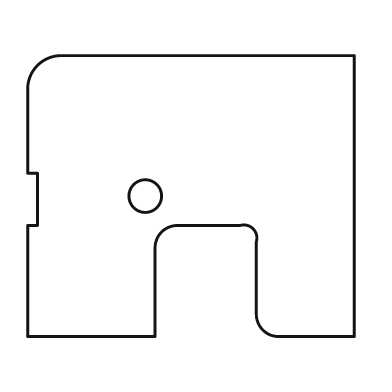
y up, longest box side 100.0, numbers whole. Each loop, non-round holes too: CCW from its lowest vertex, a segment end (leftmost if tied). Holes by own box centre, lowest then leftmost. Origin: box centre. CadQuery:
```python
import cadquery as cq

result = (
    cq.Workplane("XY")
    .moveTo(-50.0, -43.0)
    .lineTo(-11.0, -43.0)
    .lineTo(-11.0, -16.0)
    .threePointArc((-9.0, -11.0), (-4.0, -9.0))
    .lineTo(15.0, -9.0)
    .threePointArc((19.0, -10.0), (20.0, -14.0))
    .lineTo(20.0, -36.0)
    .threePointArc((22.0, -41.0), (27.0, -43.0))
    .lineTo(50.0, -43.0)
    .lineTo(50.0, 43.0)
    .lineTo(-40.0, 43.0)
    .threePointArc((-47.0, 40.0), (-50.0, 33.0))
    .lineTo(-50.0, 7.0)
    .lineTo(-47.0, 7.0)
    .lineTo(-47.0, -9.0)
    .lineTo(-50.0, -9.0)
    .close()
    .moveTo(-14.0, 0.0)
    .circle(5.0)
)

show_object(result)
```